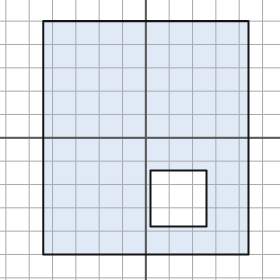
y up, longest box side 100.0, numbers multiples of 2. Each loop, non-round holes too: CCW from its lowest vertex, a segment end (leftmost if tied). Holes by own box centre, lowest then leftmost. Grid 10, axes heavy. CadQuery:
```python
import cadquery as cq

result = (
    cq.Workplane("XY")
    .moveTo(-44.0, -50.0)
    .lineTo(44.0, -50.0)
    .lineTo(44.0, 50.0)
    .lineTo(-44.0, 50.0)
    .close()
    .moveTo(2.0, -38.0)
    .lineTo(26.0, -38.0)
    .lineTo(26.0, -14.0)
    .lineTo(2.0, -14.0)
    .close()
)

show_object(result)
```